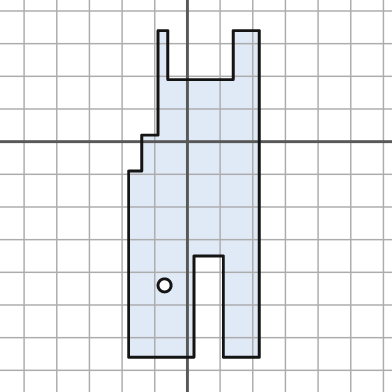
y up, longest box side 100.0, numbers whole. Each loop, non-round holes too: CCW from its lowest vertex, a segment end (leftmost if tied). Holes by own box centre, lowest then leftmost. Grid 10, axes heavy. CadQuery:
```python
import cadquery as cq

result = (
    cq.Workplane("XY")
    .moveTo(-18.0, -66.0)
    .lineTo(2.0, -66.0)
    .lineTo(2.0, -35.0)
    .lineTo(11.0, -35.0)
    .lineTo(11.0, -66.0)
    .lineTo(22.0, -66.0)
    .lineTo(22.0, 34.0)
    .lineTo(14.0, 34.0)
    .lineTo(14.0, 19.0)
    .lineTo(-6.0, 19.0)
    .lineTo(-6.0, 34.0)
    .lineTo(-9.0, 34.0)
    .lineTo(-9.0, 2.0)
    .lineTo(-14.0, 2.0)
    .lineTo(-14.0, -9.0)
    .lineTo(-18.0, -9.0)
    .close()
    .moveTo(-7.0, -44.0)
    .circle(2.0)
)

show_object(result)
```